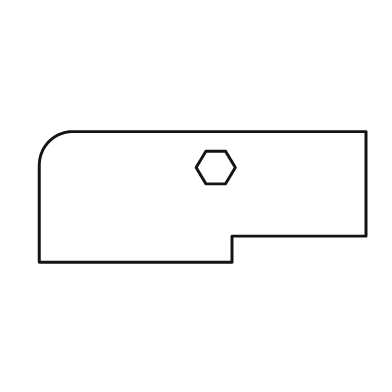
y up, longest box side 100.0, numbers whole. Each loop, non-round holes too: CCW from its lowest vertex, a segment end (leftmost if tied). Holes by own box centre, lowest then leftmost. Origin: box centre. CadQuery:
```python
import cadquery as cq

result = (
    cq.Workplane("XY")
    .moveTo(-50.0, -20.0)
    .lineTo(9.0, -20.0)
    .lineTo(9.0, -12.0)
    .lineTo(50.0, -12.0)
    .lineTo(50.0, 20.0)
    .lineTo(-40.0, 20.0)
    .threePointArc((-47.0, 17.0), (-50.0, 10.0))
    .close()
    .moveTo(1.0, 4.0)
    .lineTo(7.0, 4.0)
    .lineTo(10.0, 9.0)
    .lineTo(7.0, 14.0)
    .lineTo(1.0, 14.0)
    .lineTo(-2.0, 9.0)
    .close()
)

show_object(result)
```